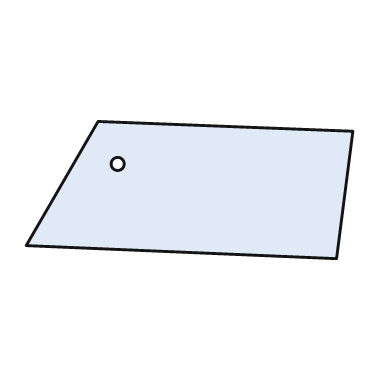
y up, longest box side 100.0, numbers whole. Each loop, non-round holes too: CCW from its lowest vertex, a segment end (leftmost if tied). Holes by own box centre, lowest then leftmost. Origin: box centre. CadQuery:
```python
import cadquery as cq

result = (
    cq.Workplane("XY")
    .moveTo(45.0, -21.0)
    .lineTo(50.0, 18.0)
    .lineTo(-28.0, 21.0)
    .lineTo(-50.0, -17.0)
    .close()
    .moveTo(-22.0, 8.0)
    .circle(2.0)
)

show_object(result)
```